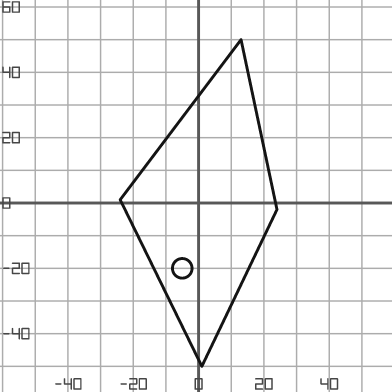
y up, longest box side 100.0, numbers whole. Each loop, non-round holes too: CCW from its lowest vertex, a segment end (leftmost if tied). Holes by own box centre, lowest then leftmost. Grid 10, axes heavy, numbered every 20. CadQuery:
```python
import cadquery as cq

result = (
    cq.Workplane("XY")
    .moveTo(1.0, -50.0)
    .lineTo(24.0, -2.0)
    .lineTo(13.0, 50.0)
    .lineTo(-24.0, 1.0)
    .close()
    .moveTo(-5.0, -20.0)
    .circle(3.0)
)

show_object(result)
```